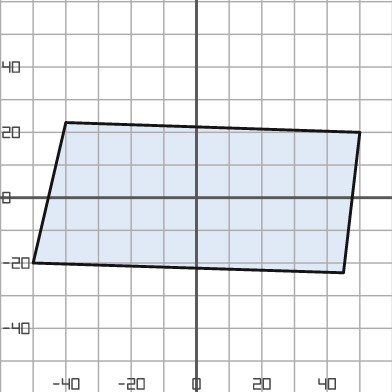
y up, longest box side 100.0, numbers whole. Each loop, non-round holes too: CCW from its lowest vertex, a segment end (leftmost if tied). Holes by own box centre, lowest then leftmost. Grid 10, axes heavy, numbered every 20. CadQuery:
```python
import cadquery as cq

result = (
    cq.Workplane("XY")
    .moveTo(45.0, -23.0)
    .lineTo(50.0, 20.0)
    .lineTo(-40.0, 23.0)
    .lineTo(-50.0, -20.0)
    .close()
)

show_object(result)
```